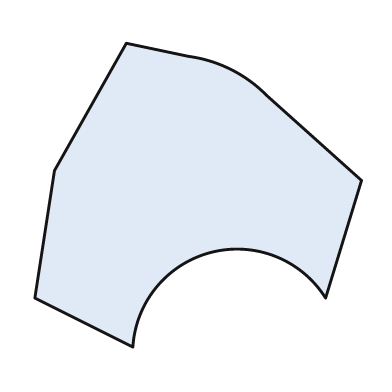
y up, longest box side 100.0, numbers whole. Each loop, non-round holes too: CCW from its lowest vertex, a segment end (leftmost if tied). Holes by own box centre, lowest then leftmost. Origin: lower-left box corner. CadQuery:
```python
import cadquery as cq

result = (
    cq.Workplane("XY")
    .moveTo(30.0, 0.0)
    .threePointArc((54.0, 29.0), (89.0, 15.0))
    .lineTo(100.0, 51.0)
    .lineTo(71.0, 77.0)
    .threePointArc((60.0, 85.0), (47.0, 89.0))
    .lineTo(28.0, 93.0)
    .lineTo(6.0, 54.0)
    .lineTo(0.0, 15.0)
    .close()
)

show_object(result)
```